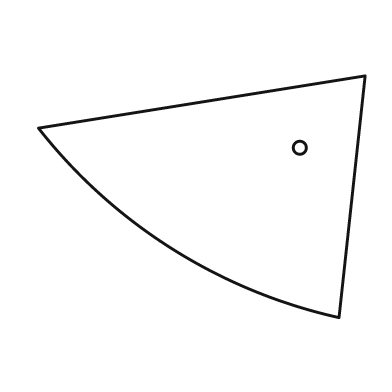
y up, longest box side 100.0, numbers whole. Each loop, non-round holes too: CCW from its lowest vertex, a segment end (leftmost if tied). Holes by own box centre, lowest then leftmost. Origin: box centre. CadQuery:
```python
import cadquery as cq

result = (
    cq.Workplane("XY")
    .moveTo(42.0, -37.0)
    .lineTo(50.0, 37.0)
    .lineTo(-50.0, 21.0)
    .threePointArc((-9.0, -16.0), (42.0, -37.0))
    .close()
    .moveTo(30.0, 15.0)
    .circle(2.0)
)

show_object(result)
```